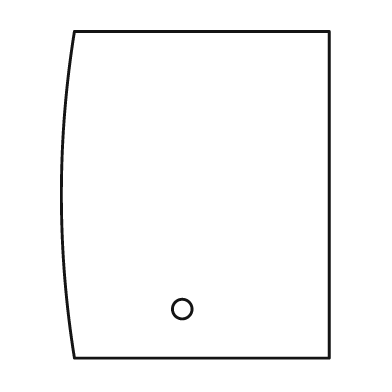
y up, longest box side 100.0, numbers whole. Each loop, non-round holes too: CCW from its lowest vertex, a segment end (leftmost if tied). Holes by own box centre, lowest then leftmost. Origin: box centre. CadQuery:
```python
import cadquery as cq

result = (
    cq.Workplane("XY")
    .moveTo(-37.0, -50.0)
    .lineTo(41.0, -50.0)
    .lineTo(41.0, 50.0)
    .lineTo(-37.0, 50.0)
    .threePointArc((-41.0, 0.0), (-37.0, -50.0))
    .close()
    .moveTo(-4.0, -35.0)
    .circle(3.0)
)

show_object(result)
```